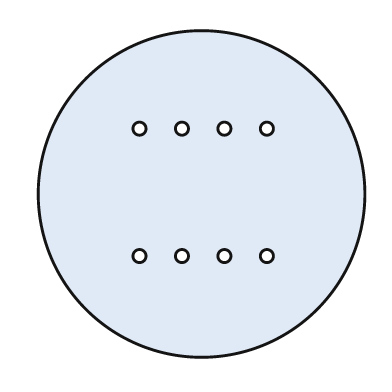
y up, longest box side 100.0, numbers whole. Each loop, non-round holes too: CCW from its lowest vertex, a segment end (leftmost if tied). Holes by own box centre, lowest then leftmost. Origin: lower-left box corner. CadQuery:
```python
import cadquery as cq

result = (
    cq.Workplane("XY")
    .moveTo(50.0, 50.0)
    .circle(50.0)
    .moveTo(31.0, 31.0)
    .circle(2.0)
    .moveTo(44.0, 31.0)
    .circle(2.0)
    .moveTo(57.0, 31.0)
    .circle(2.0)
    .moveTo(70.0, 31.0)
    .circle(2.0)
    .moveTo(31.0, 70.0)
    .circle(2.0)
    .moveTo(44.0, 70.0)
    .circle(2.0)
    .moveTo(57.0, 70.0)
    .circle(2.0)
    .moveTo(70.0, 70.0)
    .circle(2.0)
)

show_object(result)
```